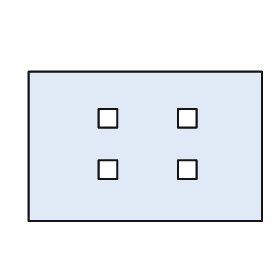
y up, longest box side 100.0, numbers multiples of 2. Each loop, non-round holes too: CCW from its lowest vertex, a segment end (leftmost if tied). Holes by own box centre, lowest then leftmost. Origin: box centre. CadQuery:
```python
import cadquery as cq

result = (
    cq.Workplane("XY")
    .moveTo(-50.0, -32.0)
    .lineTo(50.0, -32.0)
    .lineTo(50.0, 32.0)
    .lineTo(-50.0, 32.0)
    .close()
    .moveTo(-20.0, -14.0)
    .lineTo(-12.0, -14.0)
    .lineTo(-12.0, -6.0)
    .lineTo(-20.0, -6.0)
    .close()
    .moveTo(14.0, -14.0)
    .lineTo(22.0, -14.0)
    .lineTo(22.0, -6.0)
    .lineTo(14.0, -6.0)
    .close()
    .moveTo(-20.0, 8.0)
    .lineTo(-12.0, 8.0)
    .lineTo(-12.0, 16.0)
    .lineTo(-20.0, 16.0)
    .close()
    .moveTo(14.0, 8.0)
    .lineTo(22.0, 8.0)
    .lineTo(22.0, 16.0)
    .lineTo(14.0, 16.0)
    .close()
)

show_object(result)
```